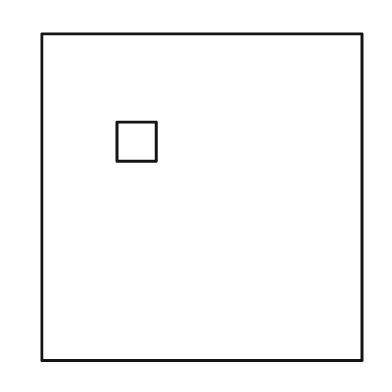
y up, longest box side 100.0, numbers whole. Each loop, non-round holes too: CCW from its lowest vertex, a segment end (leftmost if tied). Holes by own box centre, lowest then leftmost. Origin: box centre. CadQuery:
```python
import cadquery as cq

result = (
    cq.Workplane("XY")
    .moveTo(-49.0, -50.0)
    .lineTo(49.0, -50.0)
    .lineTo(49.0, 50.0)
    .lineTo(-49.0, 50.0)
    .close()
    .moveTo(-26.0, 11.0)
    .lineTo(-14.0, 11.0)
    .lineTo(-14.0, 23.0)
    .lineTo(-26.0, 23.0)
    .close()
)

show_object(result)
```